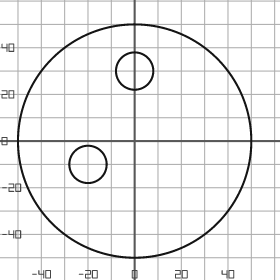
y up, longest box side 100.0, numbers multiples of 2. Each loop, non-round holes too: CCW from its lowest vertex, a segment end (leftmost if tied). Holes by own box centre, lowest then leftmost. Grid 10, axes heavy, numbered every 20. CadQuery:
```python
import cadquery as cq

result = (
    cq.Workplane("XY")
    .moveTo(0.0, 0.0)
    .circle(50.0)
    .moveTo(-20.0, -10.0)
    .circle(8.0)
    .moveTo(0.0, 30.0)
    .circle(8.0)
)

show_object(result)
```